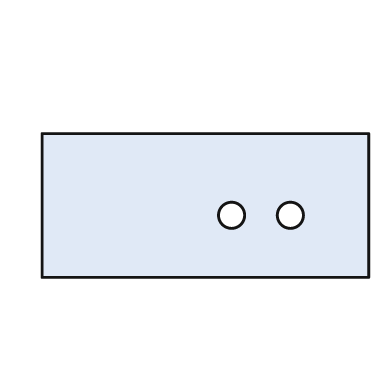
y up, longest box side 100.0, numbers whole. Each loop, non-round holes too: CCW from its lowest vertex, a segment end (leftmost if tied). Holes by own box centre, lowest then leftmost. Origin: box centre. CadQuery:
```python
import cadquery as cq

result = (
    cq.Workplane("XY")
    .moveTo(-50.0, -22.0)
    .lineTo(50.0, -22.0)
    .lineTo(50.0, 22.0)
    .lineTo(-50.0, 22.0)
    .close()
    .moveTo(8.0, -3.0)
    .circle(4.0)
    .moveTo(26.0, -3.0)
    .circle(4.0)
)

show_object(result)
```